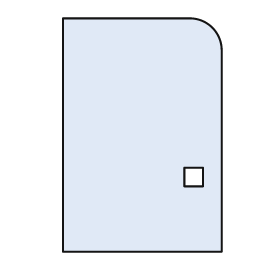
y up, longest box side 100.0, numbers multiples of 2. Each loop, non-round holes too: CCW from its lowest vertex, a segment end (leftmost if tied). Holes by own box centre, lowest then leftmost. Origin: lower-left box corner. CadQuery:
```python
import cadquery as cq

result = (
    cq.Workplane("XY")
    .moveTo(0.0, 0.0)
    .lineTo(68.0, 0.0)
    .lineTo(68.0, 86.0)
    .threePointArc((64.0, 96.0), (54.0, 100.0))
    .lineTo(0.0, 100.0)
    .close()
    .moveTo(52.0, 28.0)
    .lineTo(60.0, 28.0)
    .lineTo(60.0, 36.0)
    .lineTo(52.0, 36.0)
    .close()
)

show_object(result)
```